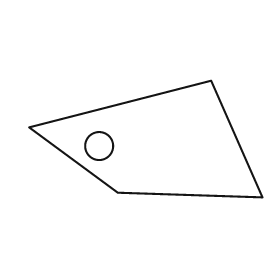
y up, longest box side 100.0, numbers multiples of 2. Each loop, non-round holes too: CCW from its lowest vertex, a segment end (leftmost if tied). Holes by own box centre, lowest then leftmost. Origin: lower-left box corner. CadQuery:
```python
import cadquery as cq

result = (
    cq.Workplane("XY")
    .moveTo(100.0, 0.0)
    .lineTo(78.0, 50.0)
    .lineTo(0.0, 30.0)
    .lineTo(38.0, 2.0)
    .close()
    .moveTo(30.0, 22.0)
    .circle(6.0)
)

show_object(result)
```